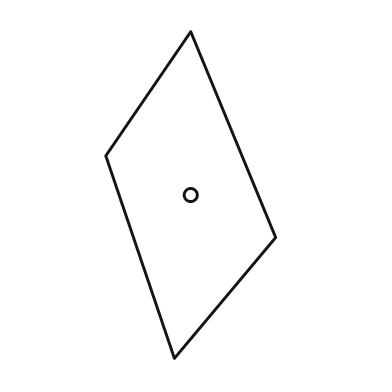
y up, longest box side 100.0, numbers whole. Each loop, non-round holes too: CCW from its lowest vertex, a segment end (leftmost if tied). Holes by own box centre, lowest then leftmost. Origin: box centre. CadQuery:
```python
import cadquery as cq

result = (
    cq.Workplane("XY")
    .moveTo(-5.0, -50.0)
    .lineTo(26.0, -13.0)
    .lineTo(0.0, 50.0)
    .lineTo(-26.0, 12.0)
    .close()
    .moveTo(0.0, 0.0)
    .circle(2.0)
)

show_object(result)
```